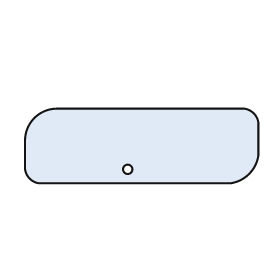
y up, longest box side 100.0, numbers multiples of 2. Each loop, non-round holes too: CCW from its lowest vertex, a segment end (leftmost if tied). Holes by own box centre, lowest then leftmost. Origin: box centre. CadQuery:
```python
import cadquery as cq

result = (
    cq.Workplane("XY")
    .moveTo(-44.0, -16.0)
    .lineTo(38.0, -16.0)
    .threePointArc((46.0, -12.0), (50.0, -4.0))
    .lineTo(50.0, 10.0)
    .threePointArc((48.0, 14.0), (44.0, 16.0))
    .lineTo(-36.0, 16.0)
    .threePointArc((-46.0, 12.0), (-50.0, 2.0))
    .lineTo(-50.0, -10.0)
    .threePointArc((-48.0, -14.0), (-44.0, -16.0))
    .close()
    .moveTo(-6.0, -10.0)
    .circle(2.0)
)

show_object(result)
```